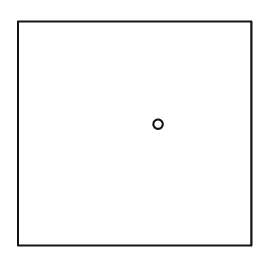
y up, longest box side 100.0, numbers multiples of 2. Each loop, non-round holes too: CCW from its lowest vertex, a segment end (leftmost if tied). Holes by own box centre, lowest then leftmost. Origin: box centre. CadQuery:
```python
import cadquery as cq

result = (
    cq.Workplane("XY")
    .moveTo(-50.0, -48.0)
    .lineTo(50.0, -48.0)
    .lineTo(50.0, 48.0)
    .lineTo(-50.0, 48.0)
    .close()
    .moveTo(10.0, 4.0)
    .circle(2.0)
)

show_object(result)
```